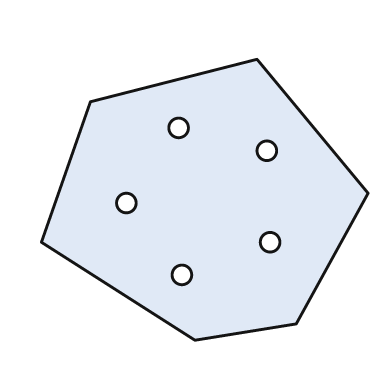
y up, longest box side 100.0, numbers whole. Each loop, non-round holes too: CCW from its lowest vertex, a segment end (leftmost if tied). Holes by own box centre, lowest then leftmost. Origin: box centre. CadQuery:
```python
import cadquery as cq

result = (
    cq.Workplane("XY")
    .moveTo(-3.0, -43.0)
    .lineTo(28.0, -38.0)
    .lineTo(50.0, 2.0)
    .lineTo(16.0, 43.0)
    .lineTo(-35.0, 30.0)
    .lineTo(-50.0, -13.0)
    .close()
    .moveTo(-7.0, -23.0)
    .circle(3.0)
    .moveTo(20.0, -13.0)
    .circle(3.0)
    .moveTo(-24.0, -1.0)
    .circle(3.0)
    .moveTo(19.0, 15.0)
    .circle(3.0)
    .moveTo(-8.0, 22.0)
    .circle(3.0)
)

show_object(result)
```